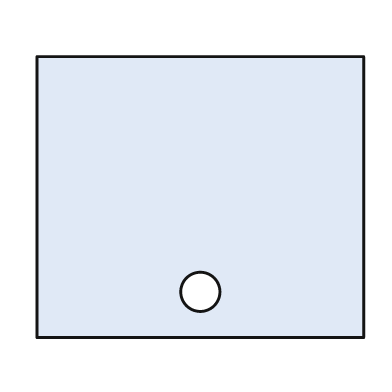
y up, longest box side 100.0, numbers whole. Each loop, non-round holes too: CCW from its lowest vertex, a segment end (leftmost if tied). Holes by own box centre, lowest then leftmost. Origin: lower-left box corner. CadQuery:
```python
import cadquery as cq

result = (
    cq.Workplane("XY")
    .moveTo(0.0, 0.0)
    .lineTo(100.0, 0.0)
    .lineTo(100.0, 86.0)
    .lineTo(0.0, 86.0)
    .close()
    .moveTo(50.0, 14.0)
    .circle(6.0)
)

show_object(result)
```